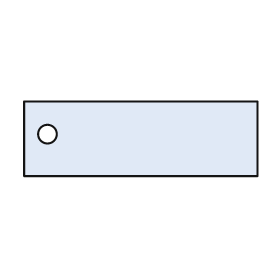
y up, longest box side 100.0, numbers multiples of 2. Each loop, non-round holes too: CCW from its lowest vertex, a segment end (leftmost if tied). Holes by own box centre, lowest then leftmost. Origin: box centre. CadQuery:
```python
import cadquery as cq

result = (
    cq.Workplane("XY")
    .moveTo(-50.0, -16.0)
    .lineTo(50.0, -16.0)
    .lineTo(50.0, 16.0)
    .lineTo(-50.0, 16.0)
    .close()
    .moveTo(-40.0, 2.0)
    .circle(4.0)
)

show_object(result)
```